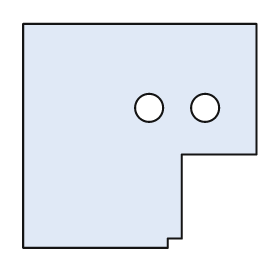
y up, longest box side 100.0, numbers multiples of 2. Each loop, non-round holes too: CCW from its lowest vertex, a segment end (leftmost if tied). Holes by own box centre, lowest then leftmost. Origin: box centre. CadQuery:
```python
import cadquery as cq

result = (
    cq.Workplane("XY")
    .moveTo(-50.0, -48.0)
    .lineTo(12.0, -48.0)
    .lineTo(12.0, -44.0)
    .lineTo(18.0, -44.0)
    .lineTo(18.0, -8.0)
    .lineTo(50.0, -8.0)
    .lineTo(50.0, 48.0)
    .lineTo(-50.0, 48.0)
    .close()
    .moveTo(4.0, 12.0)
    .circle(6.0)
    .moveTo(28.0, 12.0)
    .circle(6.0)
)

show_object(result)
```